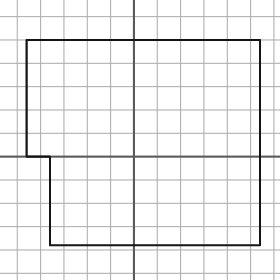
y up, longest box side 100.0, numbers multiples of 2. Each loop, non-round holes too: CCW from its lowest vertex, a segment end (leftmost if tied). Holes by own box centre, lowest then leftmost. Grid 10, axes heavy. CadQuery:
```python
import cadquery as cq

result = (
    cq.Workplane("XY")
    .moveTo(-36.0, -38.0)
    .lineTo(54.0, -38.0)
    .lineTo(54.0, 50.0)
    .lineTo(-46.0, 50.0)
    .lineTo(-46.0, 0.0)
    .lineTo(-36.0, 0.0)
    .close()
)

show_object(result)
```